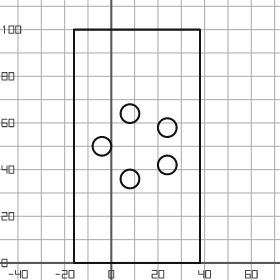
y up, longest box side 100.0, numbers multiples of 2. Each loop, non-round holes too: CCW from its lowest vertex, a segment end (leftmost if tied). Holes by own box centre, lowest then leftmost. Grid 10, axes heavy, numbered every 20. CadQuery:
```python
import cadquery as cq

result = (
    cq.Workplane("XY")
    .moveTo(-16.0, 0.0)
    .lineTo(38.0, 0.0)
    .lineTo(38.0, 100.0)
    .lineTo(-16.0, 100.0)
    .close()
    .moveTo(8.0, 36.0)
    .circle(4.0)
    .moveTo(24.0, 42.0)
    .circle(4.0)
    .moveTo(-4.0, 50.0)
    .circle(4.0)
    .moveTo(24.0, 58.0)
    .circle(4.0)
    .moveTo(8.0, 64.0)
    .circle(4.0)
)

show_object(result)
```